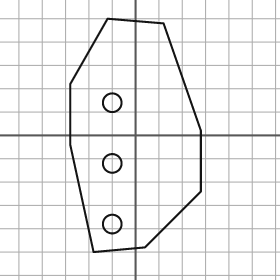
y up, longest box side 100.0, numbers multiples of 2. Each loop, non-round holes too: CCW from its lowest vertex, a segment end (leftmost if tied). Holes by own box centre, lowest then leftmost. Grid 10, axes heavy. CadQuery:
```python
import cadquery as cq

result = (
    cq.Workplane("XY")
    .moveTo(-18.0, -50.0)
    .lineTo(4.0, -48.0)
    .lineTo(28.0, -24.0)
    .lineTo(28.0, 2.0)
    .lineTo(12.0, 48.0)
    .lineTo(-12.0, 50.0)
    .lineTo(-28.0, 22.0)
    .lineTo(-28.0, -4.0)
    .close()
    .moveTo(-10.0, -38.0)
    .circle(4.0)
    .moveTo(-10.0, -12.0)
    .circle(4.0)
    .moveTo(-10.0, 14.0)
    .circle(4.0)
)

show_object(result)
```